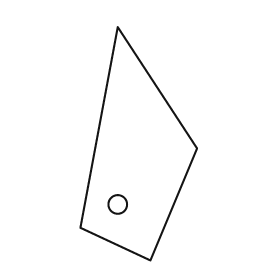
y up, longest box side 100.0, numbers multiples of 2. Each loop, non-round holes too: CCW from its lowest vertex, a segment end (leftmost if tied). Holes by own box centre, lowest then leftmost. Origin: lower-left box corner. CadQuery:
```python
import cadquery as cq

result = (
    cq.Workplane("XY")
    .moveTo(30.0, 0.0)
    .lineTo(50.0, 48.0)
    .lineTo(16.0, 100.0)
    .lineTo(0.0, 14.0)
    .close()
    .moveTo(16.0, 24.0)
    .circle(4.0)
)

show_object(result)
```